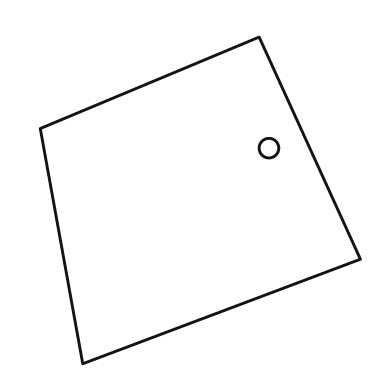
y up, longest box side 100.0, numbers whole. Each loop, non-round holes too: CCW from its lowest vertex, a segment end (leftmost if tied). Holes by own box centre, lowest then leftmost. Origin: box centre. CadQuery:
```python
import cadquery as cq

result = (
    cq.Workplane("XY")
    .moveTo(-36.0, -50.0)
    .lineTo(49.0, -18.0)
    .lineTo(18.0, 50.0)
    .lineTo(-49.0, 22.0)
    .close()
    .moveTo(21.0, 16.0)
    .circle(3.0)
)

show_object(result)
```